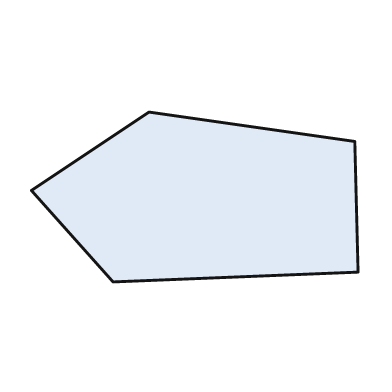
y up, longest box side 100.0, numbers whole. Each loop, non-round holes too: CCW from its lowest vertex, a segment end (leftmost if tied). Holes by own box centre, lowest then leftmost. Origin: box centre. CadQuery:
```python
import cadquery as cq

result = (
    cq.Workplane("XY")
    .moveTo(-25.0, -26.0)
    .lineTo(50.0, -23.0)
    .lineTo(49.0, 17.0)
    .lineTo(-14.0, 26.0)
    .lineTo(-50.0, 2.0)
    .close()
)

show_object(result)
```